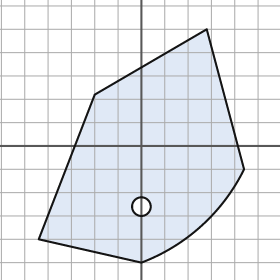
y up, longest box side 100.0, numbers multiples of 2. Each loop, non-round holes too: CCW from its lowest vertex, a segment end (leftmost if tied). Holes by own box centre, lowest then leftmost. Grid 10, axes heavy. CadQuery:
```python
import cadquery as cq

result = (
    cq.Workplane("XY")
    .moveTo(0.0, -50.0)
    .threePointArc((26.0, -34.0), (44.0, -10.0))
    .lineTo(28.0, 50.0)
    .lineTo(-20.0, 22.0)
    .lineTo(-44.0, -40.0)
    .close()
    .moveTo(0.0, -26.0)
    .circle(4.0)
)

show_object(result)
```